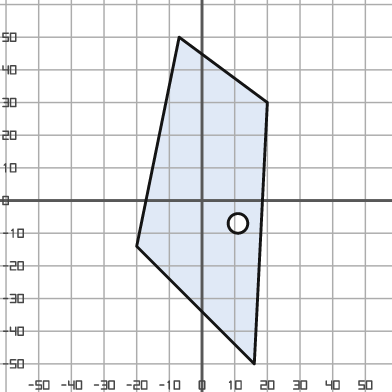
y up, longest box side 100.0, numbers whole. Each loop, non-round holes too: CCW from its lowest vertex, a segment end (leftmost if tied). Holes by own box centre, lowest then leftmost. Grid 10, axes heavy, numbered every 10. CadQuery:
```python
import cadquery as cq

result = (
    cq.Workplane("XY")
    .moveTo(16.0, -50.0)
    .lineTo(20.0, 30.0)
    .lineTo(-7.0, 50.0)
    .lineTo(-20.0, -14.0)
    .close()
    .moveTo(11.0, -7.0)
    .circle(3.0)
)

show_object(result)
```